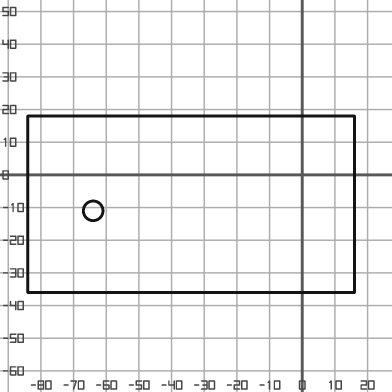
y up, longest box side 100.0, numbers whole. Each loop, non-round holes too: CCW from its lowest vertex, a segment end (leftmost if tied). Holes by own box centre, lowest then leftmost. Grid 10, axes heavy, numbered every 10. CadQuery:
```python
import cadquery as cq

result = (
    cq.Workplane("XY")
    .moveTo(-84.0, -36.0)
    .lineTo(16.0, -36.0)
    .lineTo(16.0, 18.0)
    .lineTo(-84.0, 18.0)
    .close()
    .moveTo(-64.0, -11.0)
    .circle(3.0)
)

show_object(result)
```